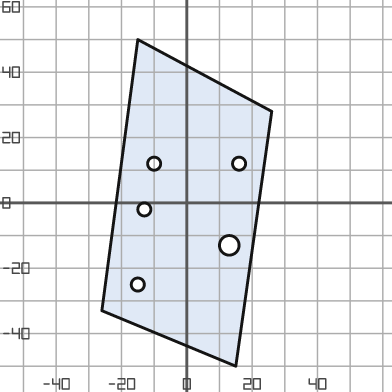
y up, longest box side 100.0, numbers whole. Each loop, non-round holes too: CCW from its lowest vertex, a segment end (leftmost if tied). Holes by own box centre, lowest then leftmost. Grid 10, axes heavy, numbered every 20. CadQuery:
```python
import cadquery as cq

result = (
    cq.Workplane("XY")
    .moveTo(15.0, -50.0)
    .lineTo(26.0, 28.0)
    .lineTo(-15.0, 50.0)
    .lineTo(-26.0, -33.0)
    .close()
    .moveTo(-15.0, -25.0)
    .circle(2.0)
    .moveTo(13.0, -13.0)
    .circle(3.0)
    .moveTo(-13.0, -2.0)
    .circle(2.0)
    .moveTo(-10.0, 12.0)
    .circle(2.0)
    .moveTo(16.0, 12.0)
    .circle(2.0)
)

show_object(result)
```